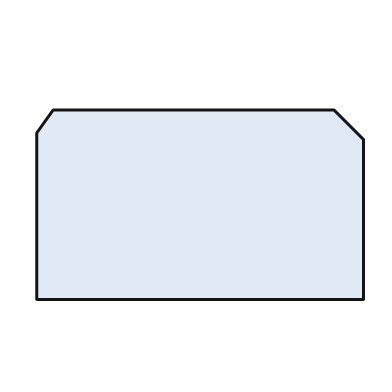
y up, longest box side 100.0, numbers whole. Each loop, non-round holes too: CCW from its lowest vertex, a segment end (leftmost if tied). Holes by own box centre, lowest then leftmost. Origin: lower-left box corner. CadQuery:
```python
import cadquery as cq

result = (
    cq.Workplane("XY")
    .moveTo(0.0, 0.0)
    .lineTo(100.0, 0.0)
    .lineTo(100.0, 49.0)
    .lineTo(91.0, 58.0)
    .lineTo(5.0, 58.0)
    .lineTo(0.0, 51.0)
    .close()
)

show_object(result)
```